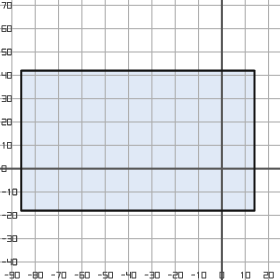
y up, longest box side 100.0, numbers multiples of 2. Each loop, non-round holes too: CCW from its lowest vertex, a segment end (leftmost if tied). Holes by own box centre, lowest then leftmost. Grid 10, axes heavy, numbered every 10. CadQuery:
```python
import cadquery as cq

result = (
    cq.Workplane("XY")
    .moveTo(-86.0, -18.0)
    .lineTo(14.0, -18.0)
    .lineTo(14.0, 42.0)
    .lineTo(-86.0, 42.0)
    .close()
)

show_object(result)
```